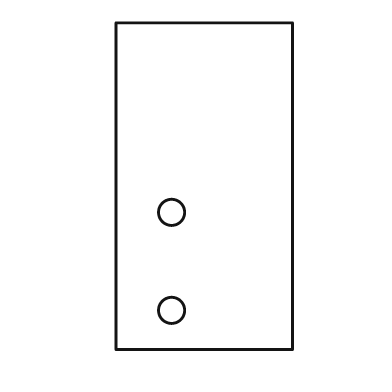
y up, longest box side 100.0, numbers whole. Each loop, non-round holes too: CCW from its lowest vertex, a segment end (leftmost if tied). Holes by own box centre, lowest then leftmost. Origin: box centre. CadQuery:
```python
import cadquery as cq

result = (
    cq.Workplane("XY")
    .moveTo(-27.0, -50.0)
    .lineTo(27.0, -50.0)
    .lineTo(27.0, 50.0)
    .lineTo(-27.0, 50.0)
    .close()
    .moveTo(-10.0, -38.0)
    .circle(4.0)
    .moveTo(-10.0, -8.0)
    .circle(4.0)
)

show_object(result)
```